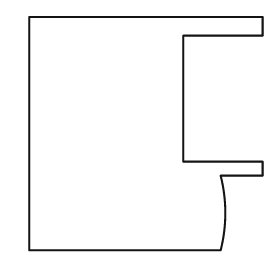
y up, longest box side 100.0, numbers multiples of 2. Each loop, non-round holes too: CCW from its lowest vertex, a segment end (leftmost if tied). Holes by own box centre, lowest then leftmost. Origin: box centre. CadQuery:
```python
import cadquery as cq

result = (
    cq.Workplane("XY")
    .moveTo(-50.0, -50.0)
    .lineTo(32.0, -50.0)
    .threePointArc((34.0, -34.0), (32.0, -18.0))
    .lineTo(50.0, -18.0)
    .lineTo(50.0, -12.0)
    .lineTo(16.0, -12.0)
    .lineTo(16.0, 42.0)
    .lineTo(50.0, 42.0)
    .lineTo(50.0, 50.0)
    .lineTo(-50.0, 50.0)
    .close()
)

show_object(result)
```